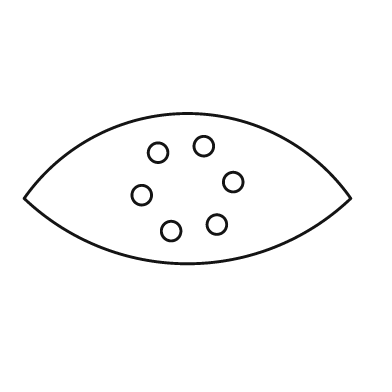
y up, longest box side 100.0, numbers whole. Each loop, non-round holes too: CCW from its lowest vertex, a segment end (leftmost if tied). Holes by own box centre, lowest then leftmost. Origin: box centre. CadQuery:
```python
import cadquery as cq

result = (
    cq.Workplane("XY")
    .moveTo(-50.0, -3.0)
    .threePointArc((0.0, -23.0), (50.0, -3.0))
    .threePointArc((0.0, 23.0), (-50.0, -3.0))
    .close()
    .moveTo(-5.0, -13.0)
    .circle(3.0)
    .moveTo(9.0, -11.0)
    .circle(3.0)
    .moveTo(-14.0, -2.0)
    .circle(3.0)
    .moveTo(14.0, 2.0)
    .circle(3.0)
    .moveTo(-9.0, 11.0)
    .circle(3.0)
    .moveTo(5.0, 13.0)
    .circle(3.0)
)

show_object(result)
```